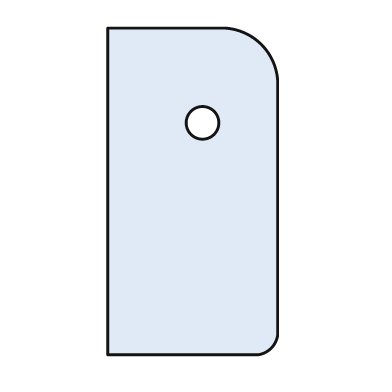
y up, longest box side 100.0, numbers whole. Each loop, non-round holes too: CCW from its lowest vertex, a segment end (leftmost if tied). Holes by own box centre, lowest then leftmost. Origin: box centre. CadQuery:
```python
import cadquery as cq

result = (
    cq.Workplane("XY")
    .moveTo(-26.0, -50.0)
    .lineTo(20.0, -50.0)
    .threePointArc((24.0, -48.0), (26.0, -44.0))
    .lineTo(26.0, 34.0)
    .threePointArc((21.0, 45.0), (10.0, 50.0))
    .lineTo(-26.0, 50.0)
    .close()
    .moveTo(3.0, 21.0)
    .circle(5.0)
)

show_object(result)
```